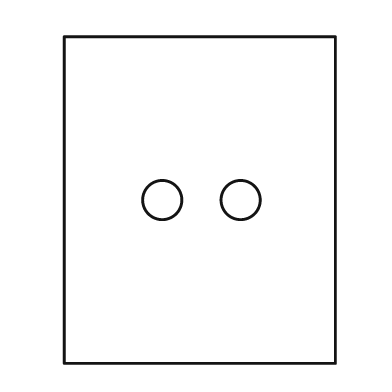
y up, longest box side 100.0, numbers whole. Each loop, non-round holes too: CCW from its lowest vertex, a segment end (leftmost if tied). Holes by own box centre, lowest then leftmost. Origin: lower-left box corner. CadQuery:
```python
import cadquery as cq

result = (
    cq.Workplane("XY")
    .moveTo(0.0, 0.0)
    .lineTo(83.0, 0.0)
    .lineTo(83.0, 100.0)
    .lineTo(0.0, 100.0)
    .close()
    .moveTo(30.0, 50.0)
    .circle(6.0)
    .moveTo(54.0, 50.0)
    .circle(6.0)
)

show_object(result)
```